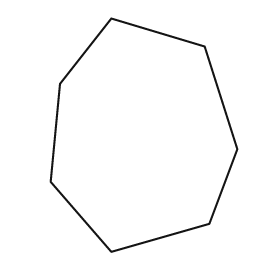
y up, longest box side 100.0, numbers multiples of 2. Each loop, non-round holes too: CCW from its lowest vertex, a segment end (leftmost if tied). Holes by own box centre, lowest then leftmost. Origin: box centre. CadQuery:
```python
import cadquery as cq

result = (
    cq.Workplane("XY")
    .moveTo(-14.0, -50.0)
    .lineTo(28.0, -38.0)
    .lineTo(40.0, -6.0)
    .lineTo(26.0, 38.0)
    .lineTo(-14.0, 50.0)
    .lineTo(-36.0, 22.0)
    .lineTo(-40.0, -20.0)
    .close()
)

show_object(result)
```